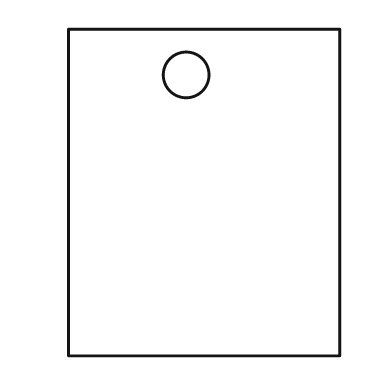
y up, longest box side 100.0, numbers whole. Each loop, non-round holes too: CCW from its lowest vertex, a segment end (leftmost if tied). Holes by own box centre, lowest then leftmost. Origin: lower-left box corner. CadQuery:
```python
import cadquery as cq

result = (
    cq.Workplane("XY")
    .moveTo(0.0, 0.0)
    .lineTo(83.0, 0.0)
    .lineTo(83.0, 100.0)
    .lineTo(0.0, 100.0)
    .close()
    .moveTo(36.0, 86.0)
    .circle(7.0)
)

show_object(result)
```